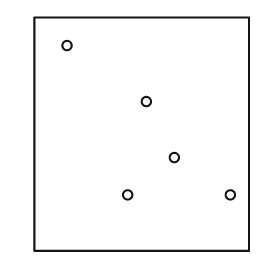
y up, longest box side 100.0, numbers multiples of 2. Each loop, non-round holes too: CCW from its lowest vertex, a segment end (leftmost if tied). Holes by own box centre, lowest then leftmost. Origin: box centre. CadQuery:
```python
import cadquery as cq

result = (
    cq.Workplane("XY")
    .moveTo(-46.0, -50.0)
    .lineTo(46.0, -50.0)
    .lineTo(46.0, 50.0)
    .lineTo(-46.0, 50.0)
    .close()
    .moveTo(-6.0, -26.0)
    .circle(2.0)
    .moveTo(38.0, -26.0)
    .circle(2.0)
    .moveTo(14.0, -10.0)
    .circle(2.0)
    .moveTo(2.0, 14.0)
    .circle(2.0)
    .moveTo(-32.0, 38.0)
    .circle(2.0)
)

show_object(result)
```